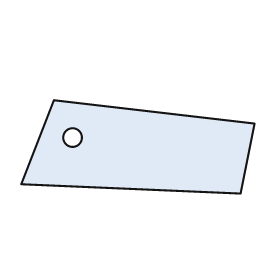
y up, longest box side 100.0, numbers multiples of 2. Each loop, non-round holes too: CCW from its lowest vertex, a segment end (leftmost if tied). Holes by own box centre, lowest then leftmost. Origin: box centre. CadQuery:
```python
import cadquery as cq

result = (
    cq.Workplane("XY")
    .moveTo(44.0, -20.0)
    .lineTo(50.0, 10.0)
    .lineTo(-36.0, 20.0)
    .lineTo(-50.0, -16.0)
    .close()
    .moveTo(-28.0, 4.0)
    .circle(4.0)
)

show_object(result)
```